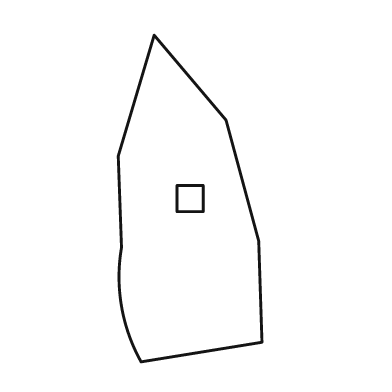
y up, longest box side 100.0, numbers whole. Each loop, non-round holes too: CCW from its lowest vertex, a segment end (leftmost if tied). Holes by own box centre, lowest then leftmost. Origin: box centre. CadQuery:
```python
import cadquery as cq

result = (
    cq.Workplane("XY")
    .moveTo(-15.0, -50.0)
    .lineTo(22.0, -44.0)
    .lineTo(21.0, -13.0)
    .lineTo(11.0, 24.0)
    .lineTo(-11.0, 50.0)
    .lineTo(-22.0, 13.0)
    .lineTo(-21.0, -15.0)
    .threePointArc((-21.0, -33.0), (-15.0, -50.0))
    .close()
    .moveTo(-4.0, -4.0)
    .lineTo(4.0, -4.0)
    .lineTo(4.0, 4.0)
    .lineTo(-4.0, 4.0)
    .close()
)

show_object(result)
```